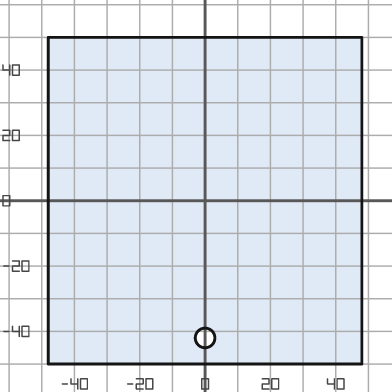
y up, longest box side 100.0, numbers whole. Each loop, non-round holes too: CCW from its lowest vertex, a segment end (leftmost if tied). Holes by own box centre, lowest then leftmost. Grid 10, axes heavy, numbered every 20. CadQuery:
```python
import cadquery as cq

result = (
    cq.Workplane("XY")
    .moveTo(-48.0, -50.0)
    .lineTo(48.0, -50.0)
    .lineTo(48.0, 50.0)
    .lineTo(-48.0, 50.0)
    .close()
    .moveTo(0.0, -42.0)
    .circle(3.0)
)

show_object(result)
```